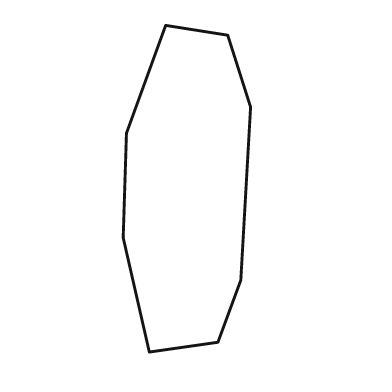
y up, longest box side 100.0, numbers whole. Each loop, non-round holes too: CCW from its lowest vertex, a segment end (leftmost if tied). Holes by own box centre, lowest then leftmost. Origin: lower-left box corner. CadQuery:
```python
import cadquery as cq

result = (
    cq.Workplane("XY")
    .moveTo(8.0, 0.0)
    .lineTo(29.0, 3.0)
    .lineTo(36.0, 22.0)
    .lineTo(39.0, 75.0)
    .lineTo(32.0, 97.0)
    .lineTo(13.0, 100.0)
    .lineTo(1.0, 67.0)
    .lineTo(0.0, 35.0)
    .close()
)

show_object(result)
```